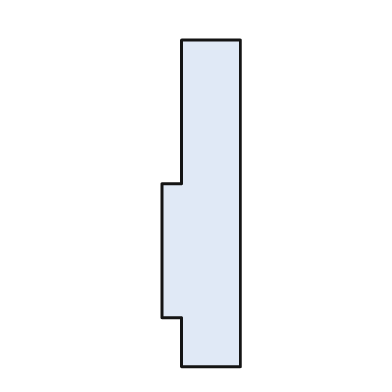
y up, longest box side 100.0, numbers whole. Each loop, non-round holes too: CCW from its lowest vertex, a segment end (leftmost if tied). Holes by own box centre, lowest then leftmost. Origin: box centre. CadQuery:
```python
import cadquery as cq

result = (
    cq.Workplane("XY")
    .moveTo(-6.0, -50.0)
    .lineTo(12.0, -50.0)
    .lineTo(12.0, 50.0)
    .lineTo(-6.0, 50.0)
    .lineTo(-6.0, 6.0)
    .lineTo(-12.0, 6.0)
    .lineTo(-12.0, -35.0)
    .lineTo(-6.0, -35.0)
    .close()
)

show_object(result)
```